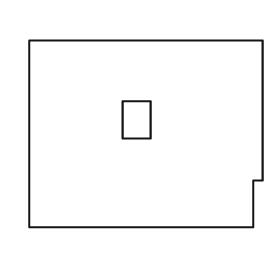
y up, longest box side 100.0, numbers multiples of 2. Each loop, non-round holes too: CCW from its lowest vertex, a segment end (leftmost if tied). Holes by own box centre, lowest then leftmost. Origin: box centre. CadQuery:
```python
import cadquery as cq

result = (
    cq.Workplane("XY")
    .moveTo(-50.0, -40.0)
    .lineTo(46.0, -40.0)
    .lineTo(46.0, -20.0)
    .lineTo(50.0, -20.0)
    .lineTo(50.0, 40.0)
    .lineTo(-50.0, 40.0)
    .close()
    .moveTo(-10.0, -2.0)
    .lineTo(2.0, -2.0)
    .lineTo(2.0, 14.0)
    .lineTo(-10.0, 14.0)
    .close()
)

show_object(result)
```